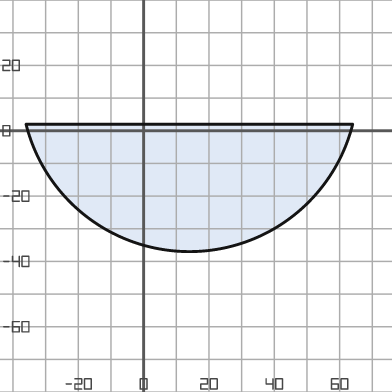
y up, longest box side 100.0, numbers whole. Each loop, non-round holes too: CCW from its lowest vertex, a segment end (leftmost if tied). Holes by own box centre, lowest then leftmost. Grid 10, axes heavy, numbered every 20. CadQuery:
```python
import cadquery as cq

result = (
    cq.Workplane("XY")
    .moveTo(-36.0, 2.0)
    .threePointArc((14.0, -37.0), (64.0, 2.0))
    .close()
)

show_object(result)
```